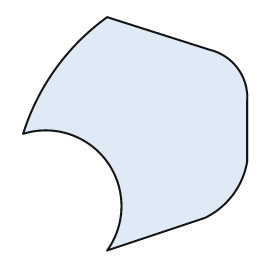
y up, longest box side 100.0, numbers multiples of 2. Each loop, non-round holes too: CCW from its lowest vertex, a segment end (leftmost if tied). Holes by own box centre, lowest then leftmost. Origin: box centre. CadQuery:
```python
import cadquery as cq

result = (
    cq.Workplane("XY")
    .moveTo(-12.0, -50.0)
    .lineTo(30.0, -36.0)
    .threePointArc((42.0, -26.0), (48.0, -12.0))
    .lineTo(48.0, 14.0)
    .threePointArc((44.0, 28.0), (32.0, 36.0))
    .lineTo(-12.0, 50.0)
    .threePointArc((-34.0, 28.0), (-48.0, 0.0))
    .threePointArc((-12.0, -12.0), (-12.0, -50.0))
    .close()
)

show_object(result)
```